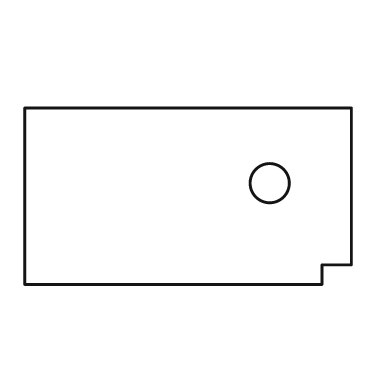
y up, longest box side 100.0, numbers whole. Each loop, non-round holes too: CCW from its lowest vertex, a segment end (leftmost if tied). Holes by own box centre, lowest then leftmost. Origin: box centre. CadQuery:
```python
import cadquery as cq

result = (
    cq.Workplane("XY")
    .moveTo(-50.0, -27.0)
    .lineTo(41.0, -27.0)
    .lineTo(41.0, -21.0)
    .lineTo(50.0, -21.0)
    .lineTo(50.0, 27.0)
    .lineTo(-50.0, 27.0)
    .close()
    .moveTo(25.0, 4.0)
    .circle(6.0)
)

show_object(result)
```